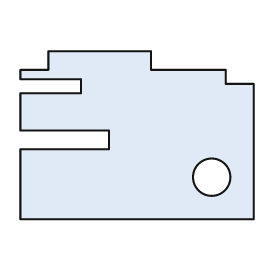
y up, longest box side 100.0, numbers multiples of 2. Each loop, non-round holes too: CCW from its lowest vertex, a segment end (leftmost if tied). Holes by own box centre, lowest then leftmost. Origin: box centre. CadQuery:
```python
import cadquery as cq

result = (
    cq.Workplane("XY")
    .moveTo(-50.0, -36.0)
    .lineTo(50.0, -36.0)
    .lineTo(50.0, 22.0)
    .lineTo(38.0, 22.0)
    .lineTo(38.0, 28.0)
    .lineTo(6.0, 28.0)
    .lineTo(6.0, 36.0)
    .lineTo(-38.0, 36.0)
    .lineTo(-38.0, 28.0)
    .lineTo(-50.0, 28.0)
    .lineTo(-50.0, 24.0)
    .lineTo(-24.0, 24.0)
    .lineTo(-24.0, 18.0)
    .lineTo(-50.0, 18.0)
    .lineTo(-50.0, 2.0)
    .lineTo(-12.0, 2.0)
    .lineTo(-12.0, -6.0)
    .lineTo(-50.0, -6.0)
    .close()
    .moveTo(32.0, -18.0)
    .circle(8.0)
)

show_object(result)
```